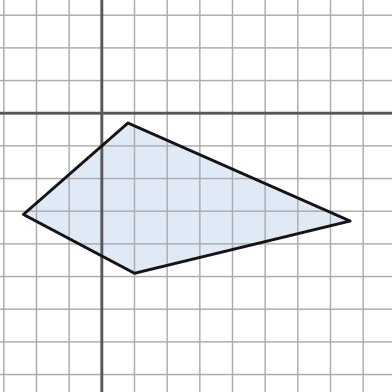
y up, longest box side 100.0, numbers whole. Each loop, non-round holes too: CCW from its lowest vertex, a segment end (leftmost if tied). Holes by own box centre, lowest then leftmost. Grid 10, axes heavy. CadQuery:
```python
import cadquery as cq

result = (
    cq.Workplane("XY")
    .moveTo(10.0, -49.0)
    .lineTo(76.0, -33.0)
    .lineTo(8.0, -3.0)
    .lineTo(-24.0, -31.0)
    .close()
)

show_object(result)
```